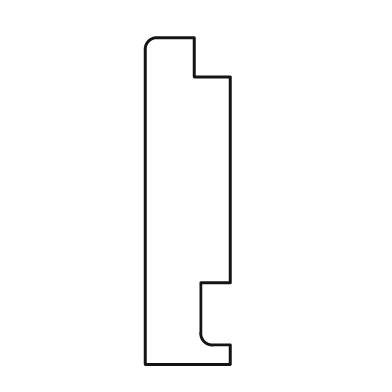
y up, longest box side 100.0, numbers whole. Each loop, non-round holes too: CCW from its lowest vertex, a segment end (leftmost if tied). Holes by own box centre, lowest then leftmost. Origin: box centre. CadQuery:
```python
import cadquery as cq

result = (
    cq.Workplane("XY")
    .moveTo(-13.0, -50.0)
    .lineTo(13.0, -50.0)
    .lineTo(13.0, -44.0)
    .lineTo(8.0, -44.0)
    .threePointArc((5.0, -43.0), (4.0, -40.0))
    .lineTo(4.0, -25.0)
    .lineTo(13.0, -25.0)
    .lineTo(13.0, 38.0)
    .lineTo(2.0, 38.0)
    .lineTo(2.0, 50.0)
    .lineTo(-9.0, 50.0)
    .threePointArc((-12.0, 49.0), (-13.0, 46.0))
    .close()
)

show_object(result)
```